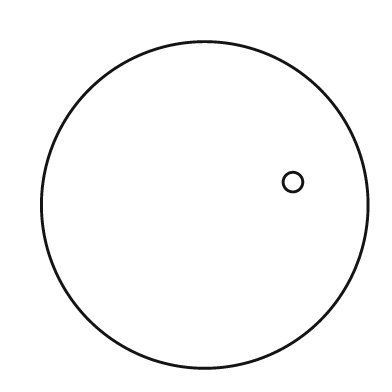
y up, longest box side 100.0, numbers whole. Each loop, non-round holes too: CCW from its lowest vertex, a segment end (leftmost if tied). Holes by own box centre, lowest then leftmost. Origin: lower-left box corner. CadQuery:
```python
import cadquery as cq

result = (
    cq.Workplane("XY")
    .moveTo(50.0, 50.0)
    .circle(50.0)
    .moveTo(77.0, 57.0)
    .circle(3.0)
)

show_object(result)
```